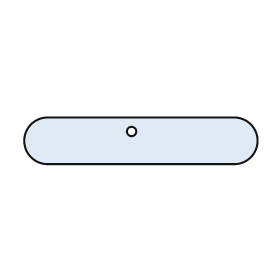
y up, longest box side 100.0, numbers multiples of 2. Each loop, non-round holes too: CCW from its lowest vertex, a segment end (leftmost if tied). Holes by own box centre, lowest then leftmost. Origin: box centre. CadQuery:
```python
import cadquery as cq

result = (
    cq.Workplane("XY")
    .moveTo(-40.0, -10.0)
    .lineTo(40.0, -10.0)
    .threePointArc((50.0, 0.0), (40.0, 10.0))
    .lineTo(-40.0, 10.0)
    .threePointArc((-50.0, 0.0), (-40.0, -10.0))
    .close()
    .moveTo(-4.0, 4.0)
    .circle(2.0)
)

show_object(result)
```